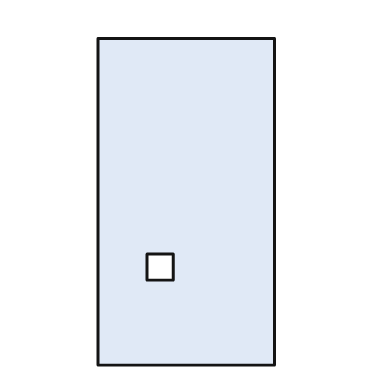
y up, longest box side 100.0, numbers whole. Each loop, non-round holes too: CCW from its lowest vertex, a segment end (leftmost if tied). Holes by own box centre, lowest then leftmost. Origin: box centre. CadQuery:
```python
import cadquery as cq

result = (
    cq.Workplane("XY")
    .moveTo(-27.0, -50.0)
    .lineTo(27.0, -50.0)
    .lineTo(27.0, 50.0)
    .lineTo(-27.0, 50.0)
    .close()
    .moveTo(-12.0, -24.0)
    .lineTo(-4.0, -24.0)
    .lineTo(-4.0, -16.0)
    .lineTo(-12.0, -16.0)
    .close()
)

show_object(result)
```